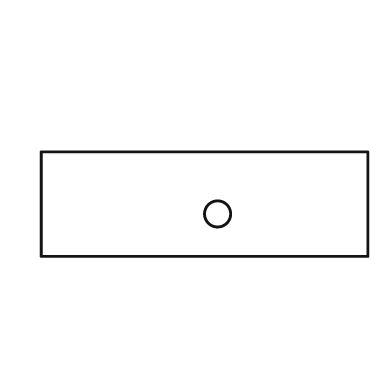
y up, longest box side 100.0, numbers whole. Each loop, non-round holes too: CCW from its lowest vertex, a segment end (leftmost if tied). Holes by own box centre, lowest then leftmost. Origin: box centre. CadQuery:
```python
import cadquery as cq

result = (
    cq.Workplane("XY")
    .moveTo(-50.0, -16.0)
    .lineTo(50.0, -16.0)
    .lineTo(50.0, 16.0)
    .lineTo(-50.0, 16.0)
    .close()
    .moveTo(4.0, -3.0)
    .circle(4.0)
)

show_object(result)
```